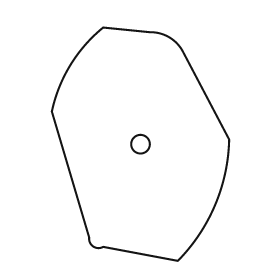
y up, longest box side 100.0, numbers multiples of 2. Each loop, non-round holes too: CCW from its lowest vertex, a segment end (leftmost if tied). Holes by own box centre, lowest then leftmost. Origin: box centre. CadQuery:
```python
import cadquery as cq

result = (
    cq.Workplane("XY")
    .moveTo(16.0, -50.0)
    .threePointArc((32.0, -26.0), (38.0, 2.0))
    .lineTo(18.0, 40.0)
    .threePointArc((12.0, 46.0), (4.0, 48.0))
    .lineTo(-16.0, 50.0)
    .threePointArc((-30.0, 34.0), (-38.0, 14.0))
    .lineTo(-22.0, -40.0)
    .threePointArc((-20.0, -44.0), (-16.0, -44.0))
    .close()
    .moveTo(0.0, 0.0)
    .circle(4.0)
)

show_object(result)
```